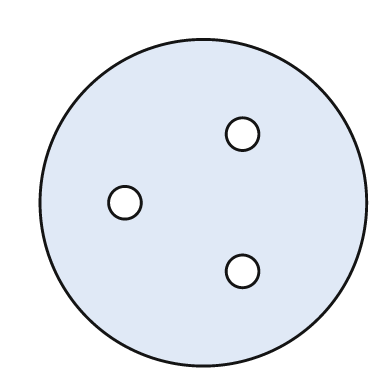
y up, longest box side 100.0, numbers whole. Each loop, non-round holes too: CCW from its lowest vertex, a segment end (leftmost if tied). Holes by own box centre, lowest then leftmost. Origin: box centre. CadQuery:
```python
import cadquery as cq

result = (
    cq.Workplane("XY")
    .moveTo(0.0, 0.0)
    .circle(50.0)
    .moveTo(12.0, -21.0)
    .circle(5.0)
    .moveTo(-24.0, 0.0)
    .circle(5.0)
    .moveTo(12.0, 21.0)
    .circle(5.0)
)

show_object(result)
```